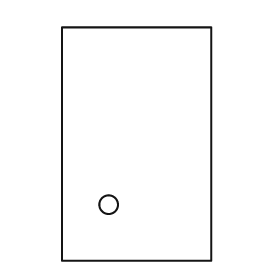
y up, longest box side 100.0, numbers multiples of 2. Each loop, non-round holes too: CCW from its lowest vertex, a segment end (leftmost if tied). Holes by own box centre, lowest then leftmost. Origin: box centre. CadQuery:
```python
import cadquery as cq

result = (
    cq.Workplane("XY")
    .moveTo(-32.0, -50.0)
    .lineTo(32.0, -50.0)
    .lineTo(32.0, 50.0)
    .lineTo(-32.0, 50.0)
    .close()
    .moveTo(-12.0, -26.0)
    .circle(4.0)
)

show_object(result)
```